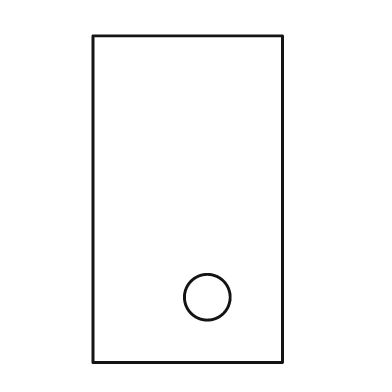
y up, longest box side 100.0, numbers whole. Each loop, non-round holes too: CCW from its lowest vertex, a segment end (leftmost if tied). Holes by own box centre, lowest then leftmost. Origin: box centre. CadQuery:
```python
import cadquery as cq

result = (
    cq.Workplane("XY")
    .moveTo(-29.0, -50.0)
    .lineTo(29.0, -50.0)
    .lineTo(29.0, 50.0)
    .lineTo(-29.0, 50.0)
    .close()
    .moveTo(6.0, -30.0)
    .circle(7.0)
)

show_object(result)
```